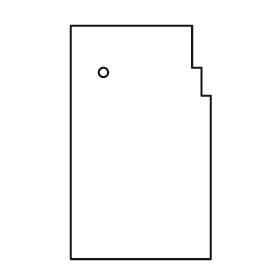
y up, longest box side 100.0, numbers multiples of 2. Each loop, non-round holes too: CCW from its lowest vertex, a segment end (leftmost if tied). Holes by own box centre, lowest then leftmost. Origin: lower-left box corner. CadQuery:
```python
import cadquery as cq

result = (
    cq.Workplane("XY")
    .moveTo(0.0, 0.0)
    .lineTo(60.0, 0.0)
    .lineTo(60.0, 70.0)
    .lineTo(56.0, 70.0)
    .lineTo(56.0, 82.0)
    .lineTo(52.0, 82.0)
    .lineTo(52.0, 100.0)
    .lineTo(0.0, 100.0)
    .close()
    .moveTo(14.0, 80.0)
    .circle(2.0)
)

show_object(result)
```